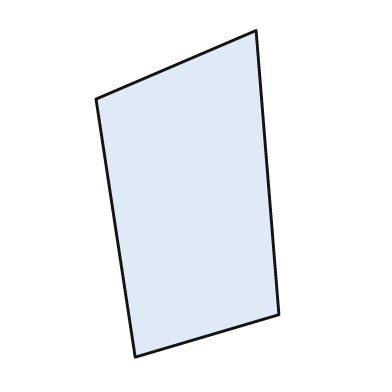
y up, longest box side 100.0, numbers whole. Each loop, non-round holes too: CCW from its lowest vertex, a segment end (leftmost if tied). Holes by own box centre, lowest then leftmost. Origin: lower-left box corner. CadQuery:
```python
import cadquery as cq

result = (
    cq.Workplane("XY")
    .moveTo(12.0, 0.0)
    .lineTo(56.0, 13.0)
    .lineTo(49.0, 100.0)
    .lineTo(0.0, 79.0)
    .close()
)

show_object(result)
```